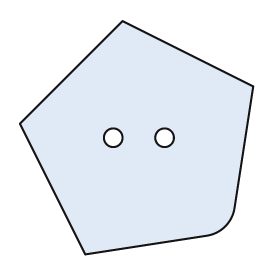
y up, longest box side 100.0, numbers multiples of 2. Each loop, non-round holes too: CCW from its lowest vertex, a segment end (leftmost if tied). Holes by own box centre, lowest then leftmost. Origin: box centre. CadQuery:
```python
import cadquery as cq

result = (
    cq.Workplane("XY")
    .moveTo(-22.0, -50.0)
    .lineTo(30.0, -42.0)
    .threePointArc((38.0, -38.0), (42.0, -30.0))
    .lineTo(50.0, 22.0)
    .lineTo(-6.0, 50.0)
    .lineTo(-50.0, 6.0)
    .close()
    .moveTo(-10.0, 0.0)
    .circle(4.0)
    .moveTo(12.0, 0.0)
    .circle(4.0)
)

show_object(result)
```